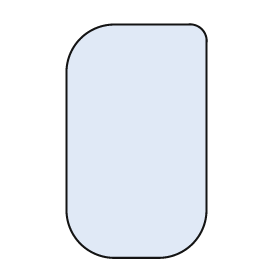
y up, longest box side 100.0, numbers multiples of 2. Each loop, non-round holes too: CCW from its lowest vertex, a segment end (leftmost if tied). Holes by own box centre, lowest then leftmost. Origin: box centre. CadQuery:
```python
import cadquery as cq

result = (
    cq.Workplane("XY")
    .moveTo(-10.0, -50.0)
    .lineTo(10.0, -50.0)
    .threePointArc((24.0, -44.0), (30.0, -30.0))
    .lineTo(30.0, 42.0)
    .threePointArc((28.0, 48.0), (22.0, 50.0))
    .lineTo(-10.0, 50.0)
    .threePointArc((-24.0, 44.0), (-30.0, 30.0))
    .lineTo(-30.0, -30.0)
    .threePointArc((-24.0, -44.0), (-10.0, -50.0))
    .close()
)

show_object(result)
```